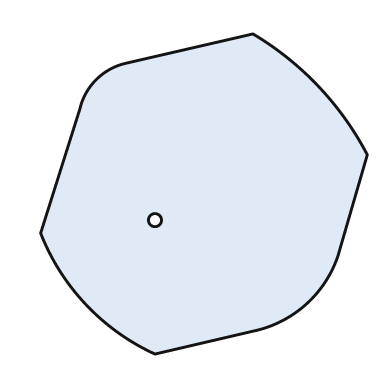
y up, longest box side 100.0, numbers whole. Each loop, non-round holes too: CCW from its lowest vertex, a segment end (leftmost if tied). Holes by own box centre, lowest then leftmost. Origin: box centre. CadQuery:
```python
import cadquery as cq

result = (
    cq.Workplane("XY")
    .moveTo(-15.0, -49.0)
    .lineTo(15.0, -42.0)
    .threePointArc((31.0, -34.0), (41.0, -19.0))
    .lineTo(50.0, 12.0)
    .threePointArc((35.0, 33.0), (15.0, 49.0))
    .lineTo(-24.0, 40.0)
    .threePointArc((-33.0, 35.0), (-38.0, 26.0))
    .lineTo(-50.0, -12.0)
    .threePointArc((-36.0, -34.0), (-15.0, -49.0))
    .close()
    .moveTo(-15.0, -8.0)
    .circle(2.0)
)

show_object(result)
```